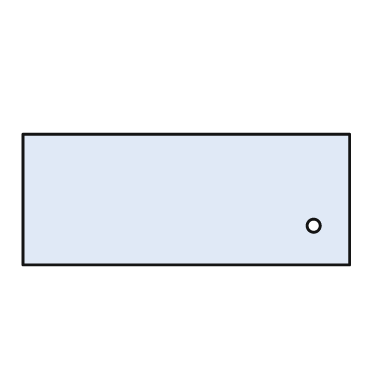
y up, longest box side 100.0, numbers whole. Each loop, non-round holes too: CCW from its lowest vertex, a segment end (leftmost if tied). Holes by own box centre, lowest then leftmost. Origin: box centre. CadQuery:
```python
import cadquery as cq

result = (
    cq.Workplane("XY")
    .moveTo(-50.0, -20.0)
    .lineTo(50.0, -20.0)
    .lineTo(50.0, 20.0)
    .lineTo(-50.0, 20.0)
    .close()
    .moveTo(39.0, -8.0)
    .circle(2.0)
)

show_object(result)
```